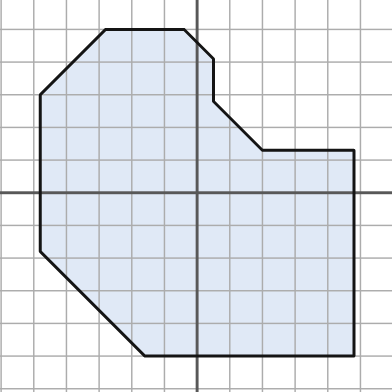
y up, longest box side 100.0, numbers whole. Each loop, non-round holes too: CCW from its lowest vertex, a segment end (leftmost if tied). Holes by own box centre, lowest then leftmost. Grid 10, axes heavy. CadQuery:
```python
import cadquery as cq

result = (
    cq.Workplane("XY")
    .moveTo(-16.0, -50.0)
    .lineTo(48.0, -50.0)
    .lineTo(48.0, 13.0)
    .lineTo(20.0, 13.0)
    .lineTo(5.0, 28.0)
    .lineTo(5.0, 41.0)
    .lineTo(-4.0, 50.0)
    .lineTo(-28.0, 50.0)
    .lineTo(-48.0, 30.0)
    .lineTo(-48.0, -18.0)
    .close()
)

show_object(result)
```